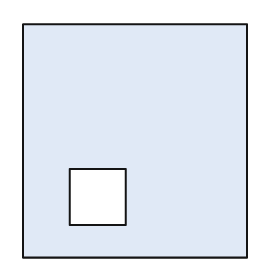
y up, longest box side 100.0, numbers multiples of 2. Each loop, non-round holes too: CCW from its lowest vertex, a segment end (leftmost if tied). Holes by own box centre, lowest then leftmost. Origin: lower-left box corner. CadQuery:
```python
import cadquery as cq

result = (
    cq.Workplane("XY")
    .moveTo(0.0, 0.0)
    .lineTo(96.0, 0.0)
    .lineTo(96.0, 100.0)
    .lineTo(0.0, 100.0)
    .close()
    .moveTo(20.0, 14.0)
    .lineTo(44.0, 14.0)
    .lineTo(44.0, 38.0)
    .lineTo(20.0, 38.0)
    .close()
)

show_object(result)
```